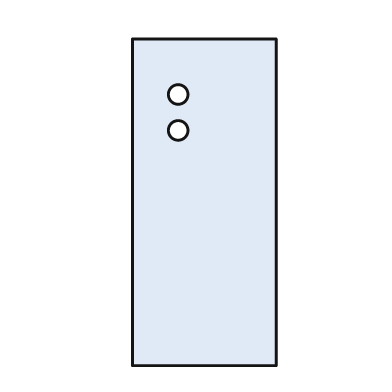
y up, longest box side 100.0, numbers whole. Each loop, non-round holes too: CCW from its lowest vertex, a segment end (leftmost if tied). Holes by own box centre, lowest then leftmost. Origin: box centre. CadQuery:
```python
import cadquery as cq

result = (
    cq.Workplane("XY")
    .moveTo(-22.0, -50.0)
    .lineTo(22.0, -50.0)
    .lineTo(22.0, 50.0)
    .lineTo(-22.0, 50.0)
    .close()
    .moveTo(-8.0, 22.0)
    .circle(3.0)
    .moveTo(-8.0, 33.0)
    .circle(3.0)
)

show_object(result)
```